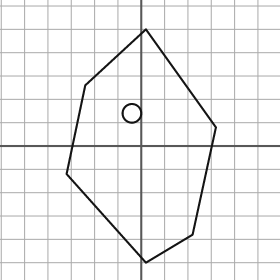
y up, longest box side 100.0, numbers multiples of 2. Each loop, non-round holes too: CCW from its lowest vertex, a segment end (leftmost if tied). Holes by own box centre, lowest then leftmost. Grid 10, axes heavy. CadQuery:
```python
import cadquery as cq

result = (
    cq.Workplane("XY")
    .moveTo(2.0, -50.0)
    .lineTo(22.0, -38.0)
    .lineTo(32.0, 8.0)
    .lineTo(2.0, 50.0)
    .lineTo(-24.0, 26.0)
    .lineTo(-32.0, -12.0)
    .close()
    .moveTo(-4.0, 14.0)
    .circle(4.0)
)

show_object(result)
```